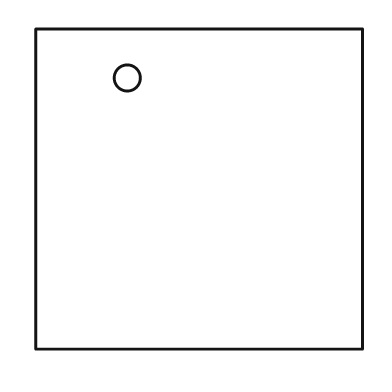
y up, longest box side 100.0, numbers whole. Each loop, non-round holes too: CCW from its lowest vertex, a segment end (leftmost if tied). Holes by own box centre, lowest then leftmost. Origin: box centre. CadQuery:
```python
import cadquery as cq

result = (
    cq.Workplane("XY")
    .moveTo(-50.0, -49.0)
    .lineTo(50.0, -49.0)
    .lineTo(50.0, 49.0)
    .lineTo(-50.0, 49.0)
    .close()
    .moveTo(-22.0, 34.0)
    .circle(4.0)
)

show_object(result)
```